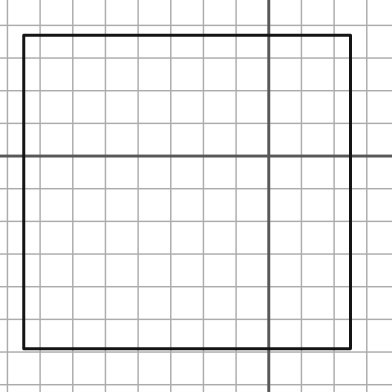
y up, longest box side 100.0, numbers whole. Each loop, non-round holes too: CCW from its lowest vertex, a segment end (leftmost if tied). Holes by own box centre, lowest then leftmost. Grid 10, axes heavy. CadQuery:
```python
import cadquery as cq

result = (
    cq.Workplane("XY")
    .moveTo(-75.0, -59.0)
    .lineTo(25.0, -59.0)
    .lineTo(25.0, 37.0)
    .lineTo(-75.0, 37.0)
    .close()
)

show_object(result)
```